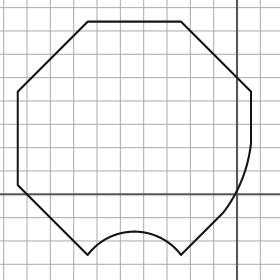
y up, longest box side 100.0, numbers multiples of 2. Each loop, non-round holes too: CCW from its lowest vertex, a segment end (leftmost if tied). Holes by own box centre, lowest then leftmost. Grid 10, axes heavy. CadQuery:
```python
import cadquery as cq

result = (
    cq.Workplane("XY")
    .moveTo(-64.0, -26.0)
    .threePointArc((-44.0, -16.0), (-24.0, -26.0))
    .lineTo(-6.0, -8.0)
    .threePointArc((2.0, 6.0), (6.0, 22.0))
    .lineTo(6.0, 44.0)
    .lineTo(-24.0, 74.0)
    .lineTo(-64.0, 74.0)
    .lineTo(-94.0, 44.0)
    .lineTo(-94.0, 4.0)
    .close()
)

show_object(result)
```